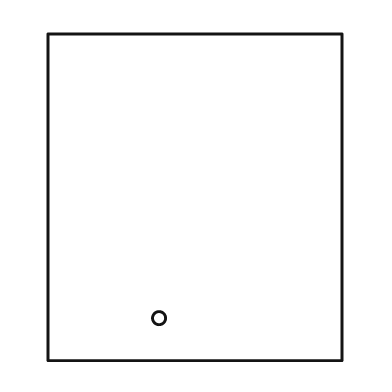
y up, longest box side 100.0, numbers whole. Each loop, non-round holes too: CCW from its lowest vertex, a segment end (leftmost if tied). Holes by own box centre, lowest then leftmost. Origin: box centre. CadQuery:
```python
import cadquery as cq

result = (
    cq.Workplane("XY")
    .moveTo(-45.0, -50.0)
    .lineTo(45.0, -50.0)
    .lineTo(45.0, 50.0)
    .lineTo(-45.0, 50.0)
    .close()
    .moveTo(-11.0, -37.0)
    .circle(2.0)
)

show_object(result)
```